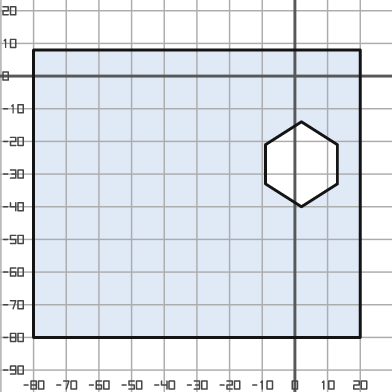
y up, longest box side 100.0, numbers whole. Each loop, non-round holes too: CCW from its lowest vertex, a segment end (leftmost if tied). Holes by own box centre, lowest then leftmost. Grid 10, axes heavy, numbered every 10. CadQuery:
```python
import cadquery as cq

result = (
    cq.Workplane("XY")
    .moveTo(-80.0, -80.0)
    .lineTo(20.0, -80.0)
    .lineTo(20.0, 8.0)
    .lineTo(-80.0, 8.0)
    .close()
    .moveTo(2.0, -40.0)
    .lineTo(13.0, -33.0)
    .lineTo(13.0, -21.0)
    .lineTo(2.0, -14.0)
    .lineTo(-9.0, -21.0)
    .lineTo(-9.0, -33.0)
    .close()
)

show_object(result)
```